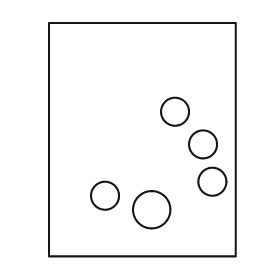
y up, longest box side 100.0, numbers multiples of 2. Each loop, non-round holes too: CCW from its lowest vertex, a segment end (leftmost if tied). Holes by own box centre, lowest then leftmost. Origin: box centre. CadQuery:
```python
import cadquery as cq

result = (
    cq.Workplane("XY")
    .moveTo(-40.0, -50.0)
    .lineTo(40.0, -50.0)
    .lineTo(40.0, 50.0)
    .lineTo(-40.0, 50.0)
    .close()
    .moveTo(4.0, -30.0)
    .circle(8.0)
    .moveTo(-16.0, -24.0)
    .circle(6.0)
    .moveTo(30.0, -18.0)
    .circle(6.0)
    .moveTo(26.0, -2.0)
    .circle(6.0)
    .moveTo(14.0, 12.0)
    .circle(6.0)
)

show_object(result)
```